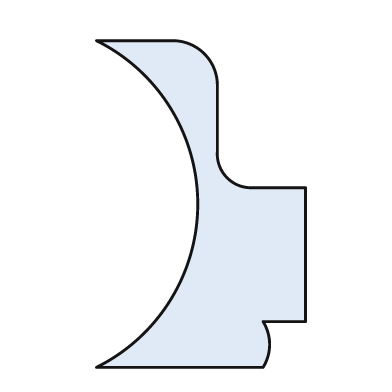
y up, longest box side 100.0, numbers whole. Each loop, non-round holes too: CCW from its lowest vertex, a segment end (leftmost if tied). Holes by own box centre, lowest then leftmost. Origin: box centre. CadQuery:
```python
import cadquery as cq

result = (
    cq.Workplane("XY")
    .moveTo(-32.0, -50.0)
    .lineTo(19.0, -50.0)
    .threePointArc((21.0, -43.0), (19.0, -36.0))
    .lineTo(32.0, -36.0)
    .lineTo(32.0, 5.0)
    .lineTo(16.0, 5.0)
    .threePointArc((8.0, 8.0), (5.0, 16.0))
    .lineTo(5.0, 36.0)
    .threePointArc((1.0, 46.0), (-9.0, 50.0))
    .lineTo(-32.0, 50.0)
    .threePointArc((-1.0, 0.0), (-32.0, -50.0))
    .close()
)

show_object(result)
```